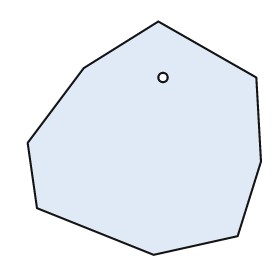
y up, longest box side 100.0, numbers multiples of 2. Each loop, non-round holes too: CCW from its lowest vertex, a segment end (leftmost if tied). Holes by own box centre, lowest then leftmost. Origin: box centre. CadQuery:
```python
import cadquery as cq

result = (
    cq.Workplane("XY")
    .moveTo(4.0, -50.0)
    .lineTo(40.0, -42.0)
    .lineTo(50.0, -10.0)
    .lineTo(48.0, 26.0)
    .lineTo(6.0, 50.0)
    .lineTo(-26.0, 30.0)
    .lineTo(-50.0, -2.0)
    .lineTo(-46.0, -30.0)
    .close()
    .moveTo(8.0, 26.0)
    .circle(2.0)
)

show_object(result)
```